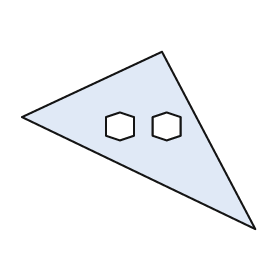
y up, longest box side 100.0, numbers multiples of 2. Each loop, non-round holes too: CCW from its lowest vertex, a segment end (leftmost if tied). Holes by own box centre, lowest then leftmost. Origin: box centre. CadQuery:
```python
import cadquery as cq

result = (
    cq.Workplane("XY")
    .moveTo(50.0, -38.0)
    .lineTo(10.0, 38.0)
    .lineTo(-50.0, 10.0)
    .close()
    .moveTo(-8.0, 0.0)
    .lineTo(-2.0, 2.0)
    .lineTo(-2.0, 10.0)
    .lineTo(-8.0, 12.0)
    .lineTo(-14.0, 10.0)
    .lineTo(-14.0, 2.0)
    .close()
    .moveTo(12.0, 0.0)
    .lineTo(18.0, 2.0)
    .lineTo(18.0, 10.0)
    .lineTo(12.0, 12.0)
    .lineTo(6.0, 10.0)
    .lineTo(6.0, 2.0)
    .close()
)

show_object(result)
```